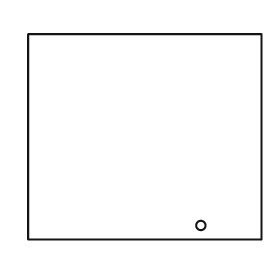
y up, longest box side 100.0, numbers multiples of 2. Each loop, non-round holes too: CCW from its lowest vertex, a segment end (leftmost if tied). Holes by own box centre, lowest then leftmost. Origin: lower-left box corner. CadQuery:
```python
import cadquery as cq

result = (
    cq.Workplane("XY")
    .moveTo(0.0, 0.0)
    .lineTo(100.0, 0.0)
    .lineTo(100.0, 88.0)
    .lineTo(0.0, 88.0)
    .close()
    .moveTo(74.0, 6.0)
    .circle(2.0)
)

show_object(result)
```